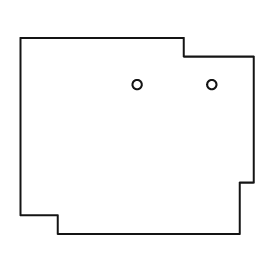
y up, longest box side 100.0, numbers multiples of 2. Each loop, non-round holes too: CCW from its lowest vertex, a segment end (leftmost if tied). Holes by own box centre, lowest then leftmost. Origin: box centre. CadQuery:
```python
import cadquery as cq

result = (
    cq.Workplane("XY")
    .moveTo(-34.0, -42.0)
    .lineTo(44.0, -42.0)
    .lineTo(44.0, -20.0)
    .lineTo(50.0, -20.0)
    .lineTo(50.0, 34.0)
    .lineTo(20.0, 34.0)
    .lineTo(20.0, 42.0)
    .lineTo(-50.0, 42.0)
    .lineTo(-50.0, -34.0)
    .lineTo(-34.0, -34.0)
    .close()
    .moveTo(0.0, 22.0)
    .circle(2.0)
    .moveTo(32.0, 22.0)
    .circle(2.0)
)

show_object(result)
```